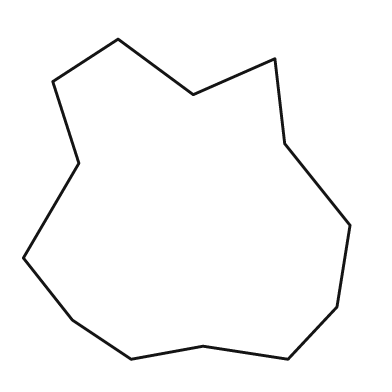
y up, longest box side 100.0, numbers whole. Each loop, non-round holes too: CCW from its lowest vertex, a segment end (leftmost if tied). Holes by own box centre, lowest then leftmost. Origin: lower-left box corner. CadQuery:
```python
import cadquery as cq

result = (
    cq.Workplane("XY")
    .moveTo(33.0, 0.0)
    .lineTo(55.0, 4.0)
    .lineTo(81.0, 0.0)
    .lineTo(96.0, 16.0)
    .lineTo(100.0, 41.0)
    .lineTo(80.0, 66.0)
    .lineTo(77.0, 92.0)
    .lineTo(52.0, 81.0)
    .lineTo(29.0, 98.0)
    .lineTo(9.0, 85.0)
    .lineTo(17.0, 60.0)
    .lineTo(0.0, 31.0)
    .lineTo(15.0, 12.0)
    .close()
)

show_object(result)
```